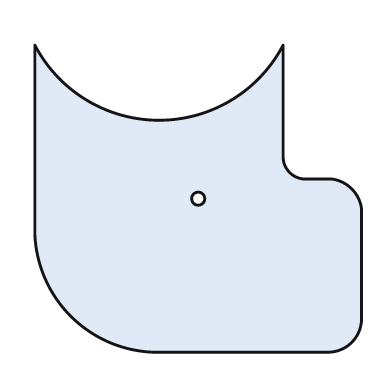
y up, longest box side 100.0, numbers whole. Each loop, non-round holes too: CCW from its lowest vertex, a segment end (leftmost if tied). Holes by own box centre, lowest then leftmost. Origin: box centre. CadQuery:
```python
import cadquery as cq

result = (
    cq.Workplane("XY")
    .moveTo(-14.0, -47.0)
    .lineTo(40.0, -47.0)
    .threePointArc((47.0, -44.0), (50.0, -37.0))
    .lineTo(50.0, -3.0)
    .threePointArc((47.0, 3.0), (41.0, 6.0))
    .lineTo(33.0, 6.0)
    .threePointArc((28.0, 8.0), (26.0, 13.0))
    .lineTo(26.0, 47.0)
    .threePointArc((-12.0, 24.0), (-50.0, 47.0))
    .lineTo(-50.0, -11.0)
    .threePointArc((-39.0, -36.0), (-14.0, -47.0))
    .close()
    .moveTo(0.0, 0.0)
    .circle(2.0)
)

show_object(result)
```